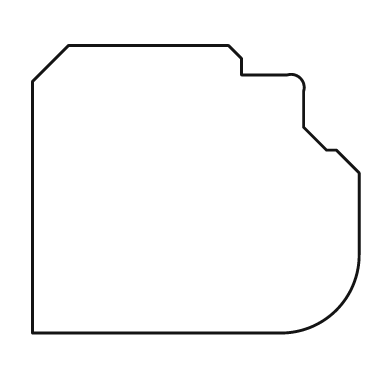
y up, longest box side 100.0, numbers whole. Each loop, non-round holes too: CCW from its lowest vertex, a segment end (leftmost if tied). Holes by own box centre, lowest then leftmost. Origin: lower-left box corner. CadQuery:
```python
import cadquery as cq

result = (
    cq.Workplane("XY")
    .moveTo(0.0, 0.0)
    .lineTo(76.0, 0.0)
    .threePointArc((93.0, 7.0), (100.0, 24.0))
    .lineTo(100.0, 49.0)
    .lineTo(93.0, 56.0)
    .lineTo(90.0, 56.0)
    .lineTo(83.0, 63.0)
    .lineTo(83.0, 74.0)
    .threePointArc((82.0, 78.0), (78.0, 79.0))
    .lineTo(64.0, 79.0)
    .lineTo(64.0, 84.0)
    .lineTo(60.0, 88.0)
    .lineTo(11.0, 88.0)
    .lineTo(0.0, 77.0)
    .close()
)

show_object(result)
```